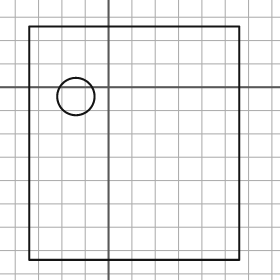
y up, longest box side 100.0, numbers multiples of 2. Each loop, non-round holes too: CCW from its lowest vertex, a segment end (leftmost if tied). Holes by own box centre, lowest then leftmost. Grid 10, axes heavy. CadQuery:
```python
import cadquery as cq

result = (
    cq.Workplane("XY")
    .moveTo(-34.0, -74.0)
    .lineTo(56.0, -74.0)
    .lineTo(56.0, 26.0)
    .lineTo(-34.0, 26.0)
    .close()
    .moveTo(-14.0, -4.0)
    .circle(8.0)
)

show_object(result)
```